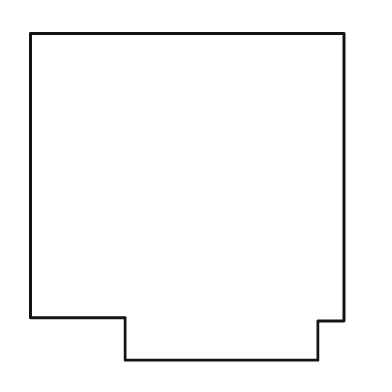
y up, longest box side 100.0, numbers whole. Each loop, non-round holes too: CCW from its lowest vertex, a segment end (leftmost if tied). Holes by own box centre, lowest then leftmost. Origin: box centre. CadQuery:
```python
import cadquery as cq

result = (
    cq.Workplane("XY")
    .moveTo(-19.0, -50.0)
    .lineTo(40.0, -50.0)
    .lineTo(40.0, -38.0)
    .lineTo(48.0, -38.0)
    .lineTo(48.0, 50.0)
    .lineTo(-48.0, 50.0)
    .lineTo(-48.0, -37.0)
    .lineTo(-19.0, -37.0)
    .close()
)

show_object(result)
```